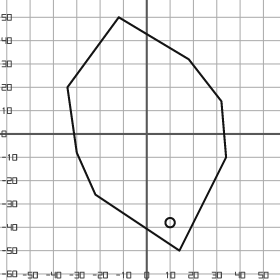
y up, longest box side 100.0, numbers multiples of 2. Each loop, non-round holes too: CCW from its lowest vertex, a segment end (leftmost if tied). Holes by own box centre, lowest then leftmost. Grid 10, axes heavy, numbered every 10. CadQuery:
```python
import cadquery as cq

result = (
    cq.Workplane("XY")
    .moveTo(14.0, -50.0)
    .lineTo(34.0, -10.0)
    .lineTo(32.0, 14.0)
    .lineTo(18.0, 32.0)
    .lineTo(-12.0, 50.0)
    .lineTo(-34.0, 20.0)
    .lineTo(-30.0, -8.0)
    .lineTo(-22.0, -26.0)
    .close()
    .moveTo(10.0, -38.0)
    .circle(2.0)
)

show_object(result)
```